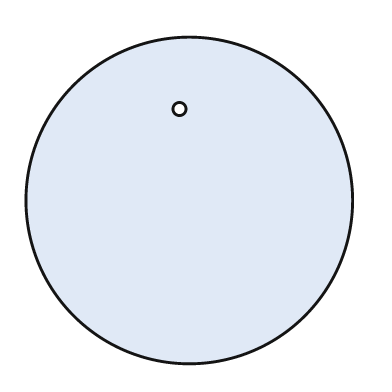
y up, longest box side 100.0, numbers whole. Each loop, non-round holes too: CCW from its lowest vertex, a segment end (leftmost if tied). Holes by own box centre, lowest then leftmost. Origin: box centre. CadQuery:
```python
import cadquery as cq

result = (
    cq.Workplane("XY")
    .moveTo(0.0, 0.0)
    .circle(50.0)
    .moveTo(-3.0, 28.0)
    .circle(2.0)
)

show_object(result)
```